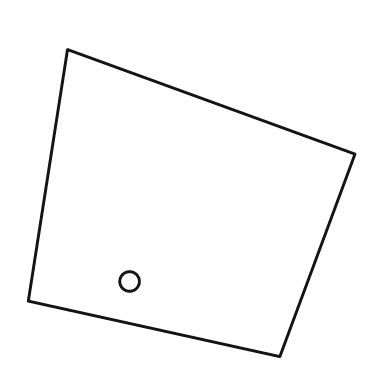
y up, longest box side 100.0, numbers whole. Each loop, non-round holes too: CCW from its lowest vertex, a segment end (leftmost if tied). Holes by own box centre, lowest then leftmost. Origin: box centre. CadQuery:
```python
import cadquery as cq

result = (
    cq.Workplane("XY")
    .moveTo(27.0, -47.0)
    .lineTo(50.0, 15.0)
    .lineTo(-38.0, 47.0)
    .lineTo(-50.0, -30.0)
    .close()
    .moveTo(-19.0, -24.0)
    .circle(3.0)
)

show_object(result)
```